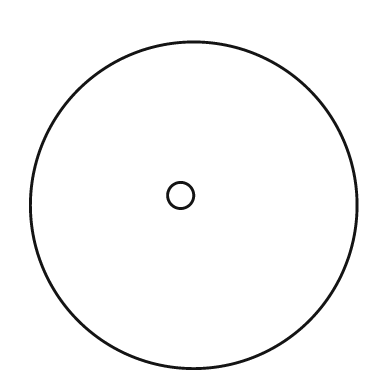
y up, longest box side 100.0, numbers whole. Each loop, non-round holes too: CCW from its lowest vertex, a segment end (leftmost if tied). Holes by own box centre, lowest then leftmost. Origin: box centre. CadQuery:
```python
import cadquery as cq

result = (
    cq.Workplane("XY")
    .moveTo(0.0, 0.0)
    .circle(50.0)
    .moveTo(-4.0, 3.0)
    .circle(4.0)
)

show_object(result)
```